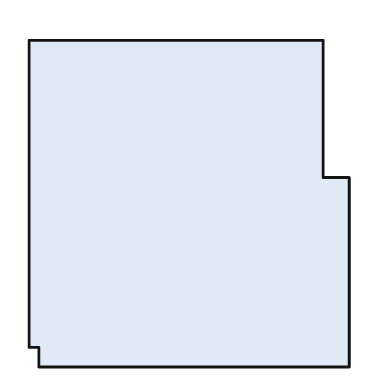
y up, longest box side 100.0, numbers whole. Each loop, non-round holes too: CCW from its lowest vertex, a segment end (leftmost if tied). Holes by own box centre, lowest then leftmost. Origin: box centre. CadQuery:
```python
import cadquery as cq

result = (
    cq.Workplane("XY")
    .moveTo(-46.0, -50.0)
    .lineTo(49.0, -50.0)
    .lineTo(49.0, 8.0)
    .lineTo(41.0, 8.0)
    .lineTo(41.0, 50.0)
    .lineTo(-49.0, 50.0)
    .lineTo(-49.0, -44.0)
    .lineTo(-46.0, -44.0)
    .close()
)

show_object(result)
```